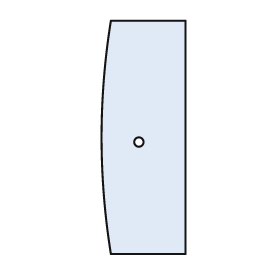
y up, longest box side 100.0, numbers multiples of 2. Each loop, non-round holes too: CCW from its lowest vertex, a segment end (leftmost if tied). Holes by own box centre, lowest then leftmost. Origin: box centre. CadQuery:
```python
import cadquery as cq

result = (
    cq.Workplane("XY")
    .moveTo(-14.0, -50.0)
    .lineTo(18.0, -50.0)
    .lineTo(18.0, 50.0)
    .lineTo(-14.0, 50.0)
    .threePointArc((-18.0, 0.0), (-14.0, -50.0))
    .close()
    .moveTo(-2.0, -2.0)
    .circle(2.0)
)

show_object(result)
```